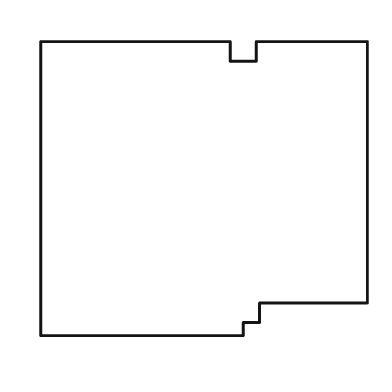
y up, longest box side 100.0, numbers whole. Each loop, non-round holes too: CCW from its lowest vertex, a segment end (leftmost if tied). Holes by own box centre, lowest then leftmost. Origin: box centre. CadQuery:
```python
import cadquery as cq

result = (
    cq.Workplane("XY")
    .moveTo(-50.0, -45.0)
    .lineTo(12.0, -45.0)
    .lineTo(12.0, -41.0)
    .lineTo(17.0, -41.0)
    .lineTo(17.0, -35.0)
    .lineTo(50.0, -35.0)
    .lineTo(50.0, 45.0)
    .lineTo(16.0, 45.0)
    .lineTo(16.0, 39.0)
    .lineTo(8.0, 39.0)
    .lineTo(8.0, 45.0)
    .lineTo(-50.0, 45.0)
    .close()
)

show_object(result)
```